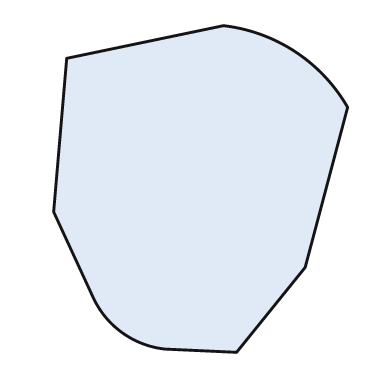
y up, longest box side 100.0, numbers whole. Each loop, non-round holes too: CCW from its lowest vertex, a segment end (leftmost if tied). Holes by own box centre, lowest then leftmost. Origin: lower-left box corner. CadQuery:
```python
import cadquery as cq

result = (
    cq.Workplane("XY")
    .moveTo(56.0, 0.0)
    .lineTo(77.0, 26.0)
    .lineTo(90.0, 75.0)
    .threePointArc((74.0, 92.0), (52.0, 100.0))
    .lineTo(4.0, 90.0)
    .lineTo(0.0, 43.0)
    .lineTo(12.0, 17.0)
    .threePointArc((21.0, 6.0), (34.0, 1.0))
    .close()
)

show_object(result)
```